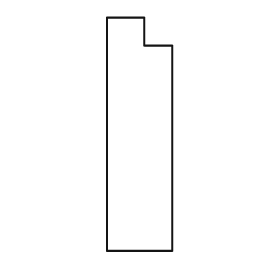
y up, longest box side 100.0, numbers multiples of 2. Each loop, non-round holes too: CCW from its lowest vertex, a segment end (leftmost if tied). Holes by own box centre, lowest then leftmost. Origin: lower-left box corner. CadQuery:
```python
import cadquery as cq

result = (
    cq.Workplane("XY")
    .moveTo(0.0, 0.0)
    .lineTo(28.0, 0.0)
    .lineTo(28.0, 88.0)
    .lineTo(16.0, 88.0)
    .lineTo(16.0, 100.0)
    .lineTo(0.0, 100.0)
    .close()
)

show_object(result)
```